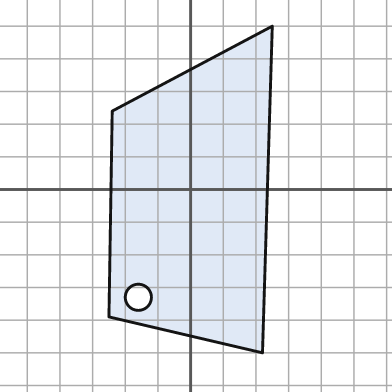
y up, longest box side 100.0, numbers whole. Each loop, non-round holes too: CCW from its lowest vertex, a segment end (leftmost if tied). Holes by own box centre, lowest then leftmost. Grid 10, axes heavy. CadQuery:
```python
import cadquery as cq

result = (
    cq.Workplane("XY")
    .moveTo(22.0, -50.0)
    .lineTo(25.0, 50.0)
    .lineTo(-24.0, 24.0)
    .lineTo(-25.0, -39.0)
    .close()
    .moveTo(-16.0, -33.0)
    .circle(4.0)
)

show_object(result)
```